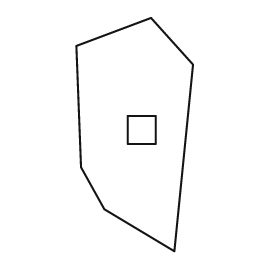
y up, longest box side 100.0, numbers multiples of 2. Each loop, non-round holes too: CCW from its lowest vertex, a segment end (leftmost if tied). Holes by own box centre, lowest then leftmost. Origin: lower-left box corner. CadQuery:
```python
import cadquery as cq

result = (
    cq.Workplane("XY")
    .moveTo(42.0, 0.0)
    .lineTo(50.0, 80.0)
    .lineTo(32.0, 100.0)
    .lineTo(0.0, 88.0)
    .lineTo(2.0, 36.0)
    .lineTo(12.0, 18.0)
    .close()
    .moveTo(22.0, 46.0)
    .lineTo(34.0, 46.0)
    .lineTo(34.0, 58.0)
    .lineTo(22.0, 58.0)
    .close()
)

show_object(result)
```